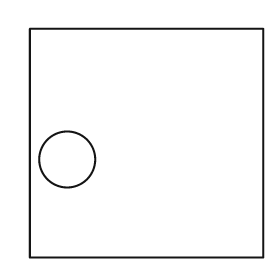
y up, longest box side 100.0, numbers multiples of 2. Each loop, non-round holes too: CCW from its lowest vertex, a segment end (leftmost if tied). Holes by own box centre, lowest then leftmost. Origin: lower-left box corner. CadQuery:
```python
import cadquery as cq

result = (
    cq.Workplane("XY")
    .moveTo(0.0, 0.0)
    .lineTo(100.0, 0.0)
    .lineTo(100.0, 98.0)
    .lineTo(0.0, 98.0)
    .close()
    .moveTo(16.0, 42.0)
    .circle(12.0)
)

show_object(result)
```